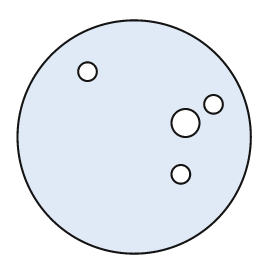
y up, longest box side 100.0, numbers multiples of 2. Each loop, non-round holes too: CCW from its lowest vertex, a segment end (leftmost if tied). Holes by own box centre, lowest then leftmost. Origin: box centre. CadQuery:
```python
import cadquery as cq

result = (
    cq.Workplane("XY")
    .moveTo(0.0, 0.0)
    .circle(50.0)
    .moveTo(20.0, -16.0)
    .circle(4.0)
    .moveTo(22.0, 6.0)
    .circle(6.0)
    .moveTo(34.0, 14.0)
    .circle(4.0)
    .moveTo(-20.0, 28.0)
    .circle(4.0)
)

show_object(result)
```